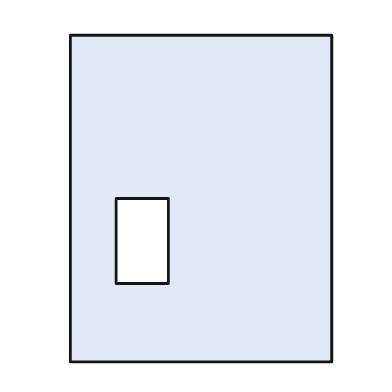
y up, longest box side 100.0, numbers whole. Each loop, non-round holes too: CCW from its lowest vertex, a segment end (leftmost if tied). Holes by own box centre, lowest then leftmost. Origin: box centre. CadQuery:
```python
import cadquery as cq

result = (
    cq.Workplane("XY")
    .moveTo(-40.0, -50.0)
    .lineTo(40.0, -50.0)
    .lineTo(40.0, 50.0)
    .lineTo(-40.0, 50.0)
    .close()
    .moveTo(-26.0, -26.0)
    .lineTo(-10.0, -26.0)
    .lineTo(-10.0, 0.0)
    .lineTo(-26.0, 0.0)
    .close()
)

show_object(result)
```